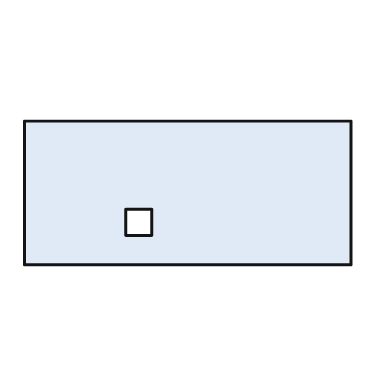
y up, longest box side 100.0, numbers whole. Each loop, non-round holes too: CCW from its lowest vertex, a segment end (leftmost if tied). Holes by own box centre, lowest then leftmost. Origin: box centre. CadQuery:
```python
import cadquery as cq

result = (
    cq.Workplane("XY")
    .moveTo(-50.0, -22.0)
    .lineTo(50.0, -22.0)
    .lineTo(50.0, 22.0)
    .lineTo(-50.0, 22.0)
    .close()
    .moveTo(-19.0, -13.0)
    .lineTo(-11.0, -13.0)
    .lineTo(-11.0, -5.0)
    .lineTo(-19.0, -5.0)
    .close()
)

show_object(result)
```